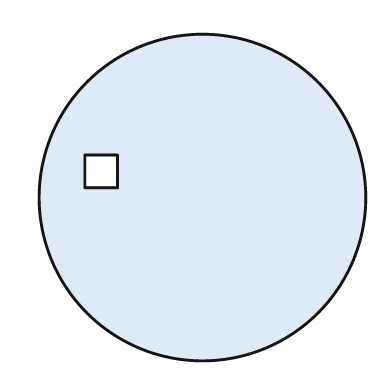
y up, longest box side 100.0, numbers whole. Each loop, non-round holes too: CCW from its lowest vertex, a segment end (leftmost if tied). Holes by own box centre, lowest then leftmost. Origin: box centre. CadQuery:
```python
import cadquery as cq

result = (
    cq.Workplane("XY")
    .moveTo(0.0, 0.0)
    .circle(50.0)
    .moveTo(-36.0, 3.0)
    .lineTo(-26.0, 3.0)
    .lineTo(-26.0, 13.0)
    .lineTo(-36.0, 13.0)
    .close()
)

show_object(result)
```